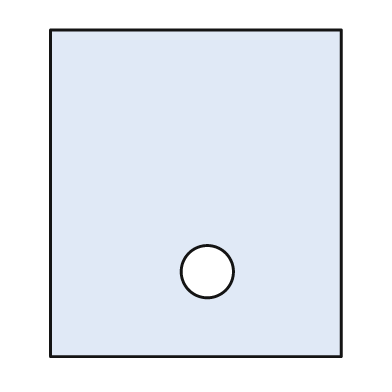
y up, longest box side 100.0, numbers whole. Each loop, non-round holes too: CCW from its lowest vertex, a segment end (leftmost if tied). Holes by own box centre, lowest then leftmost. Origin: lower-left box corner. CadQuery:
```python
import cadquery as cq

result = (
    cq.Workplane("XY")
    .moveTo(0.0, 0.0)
    .lineTo(89.0, 0.0)
    .lineTo(89.0, 100.0)
    .lineTo(0.0, 100.0)
    .close()
    .moveTo(48.0, 26.0)
    .circle(8.0)
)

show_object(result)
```